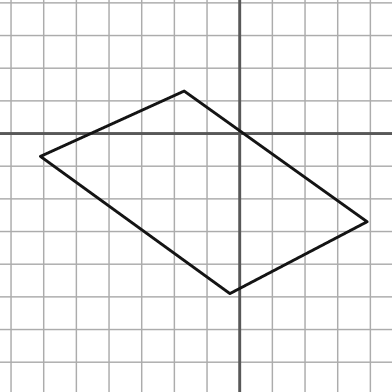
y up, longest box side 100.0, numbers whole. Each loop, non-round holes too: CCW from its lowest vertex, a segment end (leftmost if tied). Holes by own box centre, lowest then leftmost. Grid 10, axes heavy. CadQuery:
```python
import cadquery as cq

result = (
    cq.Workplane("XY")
    .moveTo(-3.0, -49.0)
    .lineTo(39.0, -27.0)
    .lineTo(-17.0, 13.0)
    .lineTo(-61.0, -7.0)
    .close()
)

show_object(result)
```